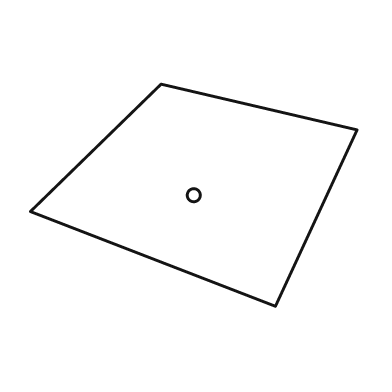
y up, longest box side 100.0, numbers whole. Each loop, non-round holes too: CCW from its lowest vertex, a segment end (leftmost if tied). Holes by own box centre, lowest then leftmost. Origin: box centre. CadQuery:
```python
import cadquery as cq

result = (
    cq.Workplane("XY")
    .moveTo(25.0, -34.0)
    .lineTo(50.0, 20.0)
    .lineTo(-10.0, 34.0)
    .lineTo(-50.0, -5.0)
    .close()
    .moveTo(0.0, 0.0)
    .circle(2.0)
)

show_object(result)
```